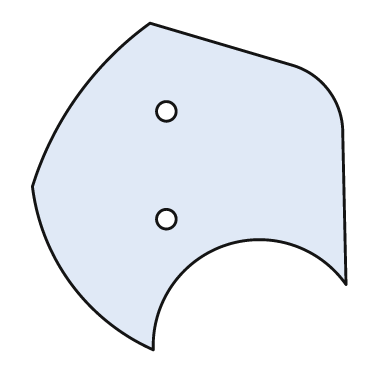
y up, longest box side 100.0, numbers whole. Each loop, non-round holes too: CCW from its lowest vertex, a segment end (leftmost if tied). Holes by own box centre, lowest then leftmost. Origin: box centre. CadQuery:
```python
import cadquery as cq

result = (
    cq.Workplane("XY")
    .moveTo(-11.0, -50.0)
    .threePointArc((11.0, -18.0), (48.0, -30.0))
    .lineTo(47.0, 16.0)
    .threePointArc((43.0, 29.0), (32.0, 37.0))
    .lineTo(-12.0, 50.0)
    .threePointArc((-34.0, 28.0), (-48.0, 0.0))
    .threePointArc((-36.0, -30.0), (-11.0, -50.0))
    .close()
    .moveTo(-7.0, -10.0)
    .circle(3.0)
    .moveTo(-7.0, 23.0)
    .circle(3.0)
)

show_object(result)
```